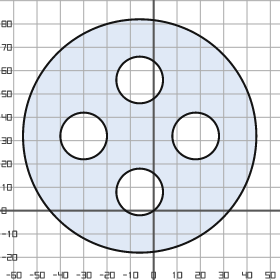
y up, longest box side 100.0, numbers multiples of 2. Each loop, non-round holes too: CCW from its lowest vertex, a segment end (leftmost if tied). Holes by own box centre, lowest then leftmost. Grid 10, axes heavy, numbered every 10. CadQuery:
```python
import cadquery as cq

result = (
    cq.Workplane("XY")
    .moveTo(-6.0, 32.0)
    .circle(50.0)
    .moveTo(-6.0, 8.0)
    .circle(10.0)
    .moveTo(-30.0, 32.0)
    .circle(10.0)
    .moveTo(18.0, 32.0)
    .circle(10.0)
    .moveTo(-6.0, 56.0)
    .circle(10.0)
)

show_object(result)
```